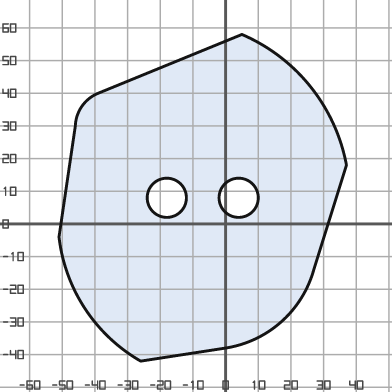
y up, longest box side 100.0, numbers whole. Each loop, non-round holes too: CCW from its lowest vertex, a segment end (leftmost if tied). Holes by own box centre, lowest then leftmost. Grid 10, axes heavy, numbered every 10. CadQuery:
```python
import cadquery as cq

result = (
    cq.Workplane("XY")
    .moveTo(-26.0, -42.0)
    .lineTo(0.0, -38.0)
    .threePointArc((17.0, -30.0), (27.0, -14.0))
    .lineTo(37.0, 18.0)
    .threePointArc((26.0, 42.0), (5.0, 58.0))
    .lineTo(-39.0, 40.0)
    .threePointArc((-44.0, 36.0), (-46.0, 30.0))
    .lineTo(-51.0, -4.0)
    .threePointArc((-43.0, -26.0), (-26.0, -42.0))
    .close()
    .moveTo(-18.0, 8.0)
    .circle(6.0)
    .moveTo(4.0, 8.0)
    .circle(6.0)
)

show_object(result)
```